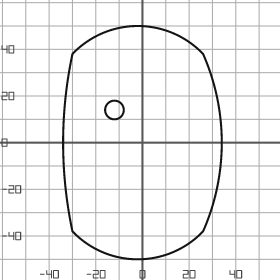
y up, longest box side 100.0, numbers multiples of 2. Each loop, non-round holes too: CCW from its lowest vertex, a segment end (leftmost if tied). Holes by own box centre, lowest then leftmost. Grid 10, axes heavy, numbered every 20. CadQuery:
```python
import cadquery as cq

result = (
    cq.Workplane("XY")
    .moveTo(-30.0, -38.0)
    .threePointArc((-2.0, -50.0), (26.0, -38.0))
    .threePointArc((34.0, 0.0), (26.0, 38.0))
    .threePointArc((-2.0, 50.0), (-30.0, 38.0))
    .threePointArc((-34.0, 0.0), (-30.0, -38.0))
    .close()
    .moveTo(-12.0, 14.0)
    .circle(4.0)
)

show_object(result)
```